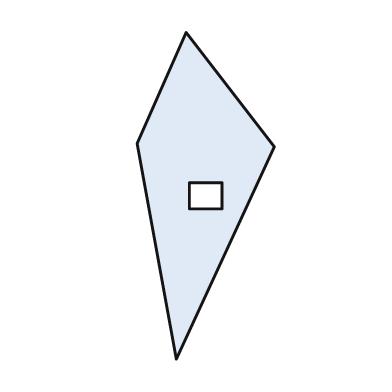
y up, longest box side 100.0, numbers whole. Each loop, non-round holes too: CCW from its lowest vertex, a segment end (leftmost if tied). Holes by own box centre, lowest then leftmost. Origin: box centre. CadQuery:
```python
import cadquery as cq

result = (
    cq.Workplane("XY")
    .moveTo(-9.0, -50.0)
    .lineTo(21.0, 15.0)
    .lineTo(-6.0, 50.0)
    .lineTo(-21.0, 16.0)
    .close()
    .moveTo(-5.0, -4.0)
    .lineTo(5.0, -4.0)
    .lineTo(5.0, 4.0)
    .lineTo(-5.0, 4.0)
    .close()
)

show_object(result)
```